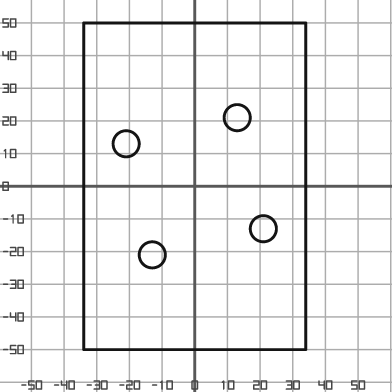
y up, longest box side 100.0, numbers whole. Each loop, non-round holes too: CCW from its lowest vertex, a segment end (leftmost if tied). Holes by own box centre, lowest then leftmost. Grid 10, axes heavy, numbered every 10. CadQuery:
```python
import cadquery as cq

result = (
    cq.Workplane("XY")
    .moveTo(-34.0, -50.0)
    .lineTo(34.0, -50.0)
    .lineTo(34.0, 50.0)
    .lineTo(-34.0, 50.0)
    .close()
    .moveTo(-13.0, -21.0)
    .circle(4.0)
    .moveTo(21.0, -13.0)
    .circle(4.0)
    .moveTo(-21.0, 13.0)
    .circle(4.0)
    .moveTo(13.0, 21.0)
    .circle(4.0)
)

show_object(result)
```